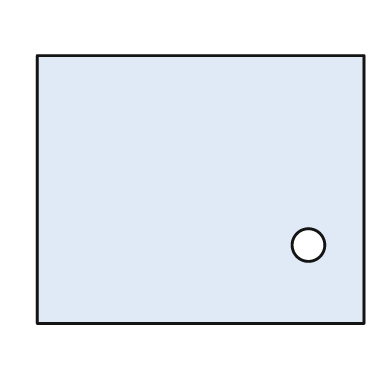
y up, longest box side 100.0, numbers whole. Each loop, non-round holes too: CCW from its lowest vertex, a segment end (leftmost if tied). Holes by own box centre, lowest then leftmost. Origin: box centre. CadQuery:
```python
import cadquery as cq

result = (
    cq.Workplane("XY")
    .moveTo(-50.0, -41.0)
    .lineTo(50.0, -41.0)
    .lineTo(50.0, 41.0)
    .lineTo(-50.0, 41.0)
    .close()
    .moveTo(33.0, -17.0)
    .circle(5.0)
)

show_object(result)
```